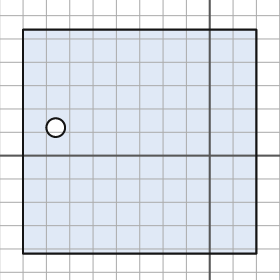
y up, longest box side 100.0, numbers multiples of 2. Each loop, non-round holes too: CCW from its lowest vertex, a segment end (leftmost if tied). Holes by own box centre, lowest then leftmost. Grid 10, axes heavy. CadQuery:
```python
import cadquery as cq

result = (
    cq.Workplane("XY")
    .moveTo(-80.0, -42.0)
    .lineTo(20.0, -42.0)
    .lineTo(20.0, 54.0)
    .lineTo(-80.0, 54.0)
    .close()
    .moveTo(-66.0, 12.0)
    .circle(4.0)
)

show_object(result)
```